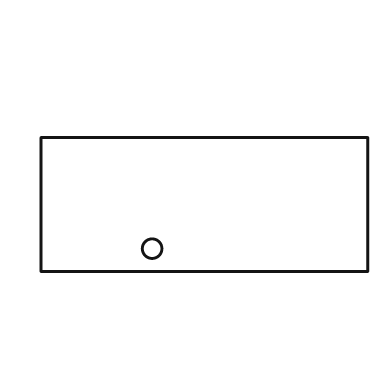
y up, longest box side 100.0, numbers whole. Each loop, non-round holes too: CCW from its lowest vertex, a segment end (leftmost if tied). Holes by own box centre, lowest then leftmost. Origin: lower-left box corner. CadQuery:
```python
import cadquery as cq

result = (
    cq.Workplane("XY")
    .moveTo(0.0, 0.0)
    .lineTo(100.0, 0.0)
    .lineTo(100.0, 41.0)
    .lineTo(0.0, 41.0)
    .close()
    .moveTo(34.0, 7.0)
    .circle(3.0)
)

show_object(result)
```